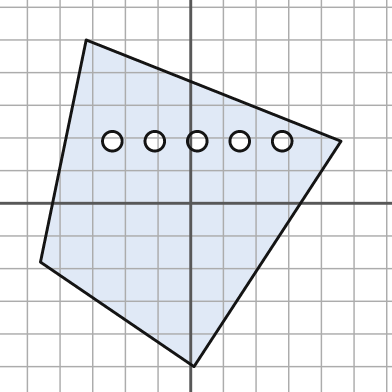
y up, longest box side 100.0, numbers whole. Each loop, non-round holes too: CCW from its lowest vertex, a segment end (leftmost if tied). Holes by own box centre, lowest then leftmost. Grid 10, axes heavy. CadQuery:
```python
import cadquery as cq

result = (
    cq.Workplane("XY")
    .moveTo(1.0, -50.0)
    .lineTo(46.0, 19.0)
    .lineTo(-32.0, 50.0)
    .lineTo(-46.0, -18.0)
    .close()
    .moveTo(-24.0, 19.0)
    .circle(3.0)
    .moveTo(-11.0, 19.0)
    .circle(3.0)
    .moveTo(2.0, 19.0)
    .circle(3.0)
    .moveTo(15.0, 19.0)
    .circle(3.0)
    .moveTo(28.0, 19.0)
    .circle(3.0)
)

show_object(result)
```